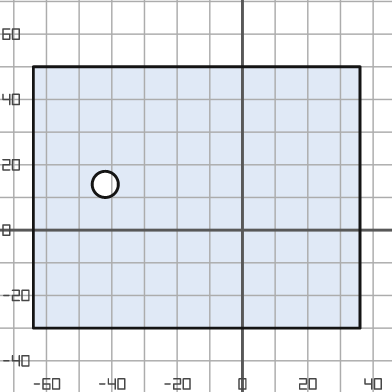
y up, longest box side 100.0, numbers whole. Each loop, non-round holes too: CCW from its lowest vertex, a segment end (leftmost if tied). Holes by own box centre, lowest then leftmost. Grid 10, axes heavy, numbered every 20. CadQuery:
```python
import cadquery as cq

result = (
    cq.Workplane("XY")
    .moveTo(-64.0, -30.0)
    .lineTo(36.0, -30.0)
    .lineTo(36.0, 50.0)
    .lineTo(-64.0, 50.0)
    .close()
    .moveTo(-42.0, 14.0)
    .circle(4.0)
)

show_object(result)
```